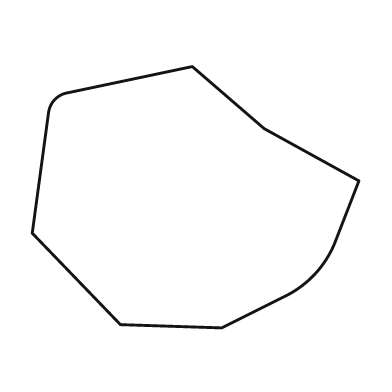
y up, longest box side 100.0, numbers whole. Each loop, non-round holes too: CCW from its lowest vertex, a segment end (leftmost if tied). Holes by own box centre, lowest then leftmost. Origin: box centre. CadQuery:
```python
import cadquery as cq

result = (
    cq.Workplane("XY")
    .moveTo(8.0, -40.0)
    .lineTo(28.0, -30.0)
    .threePointArc((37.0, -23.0), (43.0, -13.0))
    .lineTo(50.0, 5.0)
    .lineTo(21.0, 21.0)
    .lineTo(-1.0, 40.0)
    .lineTo(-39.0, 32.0)
    .threePointArc((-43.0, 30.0), (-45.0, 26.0))
    .lineTo(-50.0, -11.0)
    .lineTo(-23.0, -39.0)
    .close()
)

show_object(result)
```